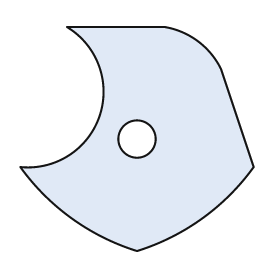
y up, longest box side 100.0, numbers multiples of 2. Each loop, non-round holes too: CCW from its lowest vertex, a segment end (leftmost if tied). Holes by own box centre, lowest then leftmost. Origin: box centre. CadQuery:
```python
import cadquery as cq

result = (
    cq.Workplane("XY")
    .moveTo(0.0, -48.0)
    .threePointArc((28.0, -34.0), (50.0, -12.0))
    .lineTo(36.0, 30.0)
    .threePointArc((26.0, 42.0), (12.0, 48.0))
    .lineTo(-30.0, 48.0)
    .threePointArc((-16.0, 10.0), (-50.0, -12.0))
    .threePointArc((-28.0, -34.0), (0.0, -48.0))
    .close()
    .moveTo(0.0, 0.0)
    .circle(8.0)
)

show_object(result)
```